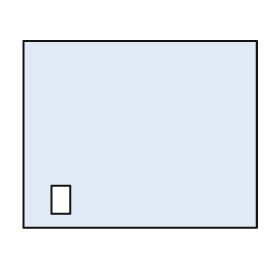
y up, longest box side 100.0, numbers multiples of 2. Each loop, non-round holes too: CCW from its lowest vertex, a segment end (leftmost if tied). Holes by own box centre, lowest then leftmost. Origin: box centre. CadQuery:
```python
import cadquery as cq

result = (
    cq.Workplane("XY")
    .moveTo(-50.0, -40.0)
    .lineTo(50.0, -40.0)
    .lineTo(50.0, 40.0)
    .lineTo(-50.0, 40.0)
    .close()
    .moveTo(-38.0, -34.0)
    .lineTo(-30.0, -34.0)
    .lineTo(-30.0, -22.0)
    .lineTo(-38.0, -22.0)
    .close()
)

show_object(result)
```